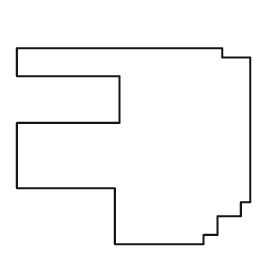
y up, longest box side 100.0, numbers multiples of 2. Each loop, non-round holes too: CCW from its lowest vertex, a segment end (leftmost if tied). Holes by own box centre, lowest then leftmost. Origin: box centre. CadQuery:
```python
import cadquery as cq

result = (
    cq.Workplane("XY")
    .moveTo(-8.0, -42.0)
    .lineTo(30.0, -42.0)
    .lineTo(30.0, -38.0)
    .lineTo(36.0, -38.0)
    .lineTo(36.0, -30.0)
    .lineTo(46.0, -30.0)
    .lineTo(46.0, -24.0)
    .lineTo(50.0, -24.0)
    .lineTo(50.0, 38.0)
    .lineTo(38.0, 38.0)
    .lineTo(38.0, 42.0)
    .lineTo(-50.0, 42.0)
    .lineTo(-50.0, 30.0)
    .lineTo(-6.0, 30.0)
    .lineTo(-6.0, 10.0)
    .lineTo(-50.0, 10.0)
    .lineTo(-50.0, -18.0)
    .lineTo(-8.0, -18.0)
    .close()
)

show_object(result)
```